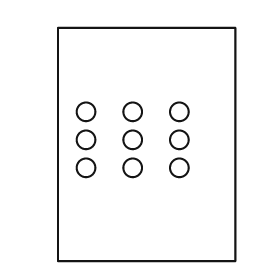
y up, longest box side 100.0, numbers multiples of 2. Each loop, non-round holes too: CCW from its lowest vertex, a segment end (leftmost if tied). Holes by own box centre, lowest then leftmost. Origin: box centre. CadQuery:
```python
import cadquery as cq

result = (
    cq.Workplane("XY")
    .moveTo(-38.0, -50.0)
    .lineTo(38.0, -50.0)
    .lineTo(38.0, 50.0)
    .lineTo(-38.0, 50.0)
    .close()
    .moveTo(-26.0, -10.0)
    .circle(4.0)
    .moveTo(-6.0, -10.0)
    .circle(4.0)
    .moveTo(14.0, -10.0)
    .circle(4.0)
    .moveTo(-26.0, 2.0)
    .circle(4.0)
    .moveTo(-6.0, 2.0)
    .circle(4.0)
    .moveTo(14.0, 2.0)
    .circle(4.0)
    .moveTo(-26.0, 14.0)
    .circle(4.0)
    .moveTo(-6.0, 14.0)
    .circle(4.0)
    .moveTo(14.0, 14.0)
    .circle(4.0)
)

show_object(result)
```